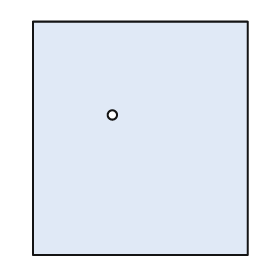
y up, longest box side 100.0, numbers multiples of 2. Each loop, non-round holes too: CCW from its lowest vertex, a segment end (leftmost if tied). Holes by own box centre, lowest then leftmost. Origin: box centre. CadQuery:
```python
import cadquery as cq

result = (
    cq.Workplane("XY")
    .moveTo(-46.0, -50.0)
    .lineTo(46.0, -50.0)
    .lineTo(46.0, 50.0)
    .lineTo(-46.0, 50.0)
    .close()
    .moveTo(-12.0, 10.0)
    .circle(2.0)
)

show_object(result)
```